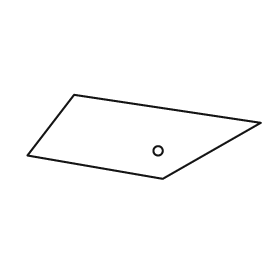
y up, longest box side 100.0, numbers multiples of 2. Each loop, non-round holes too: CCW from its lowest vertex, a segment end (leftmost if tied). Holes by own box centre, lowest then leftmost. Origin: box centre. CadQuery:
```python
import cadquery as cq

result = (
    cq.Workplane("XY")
    .moveTo(8.0, -18.0)
    .lineTo(50.0, 6.0)
    .lineTo(-30.0, 18.0)
    .lineTo(-50.0, -8.0)
    .close()
    .moveTo(6.0, -6.0)
    .circle(2.0)
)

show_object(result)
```